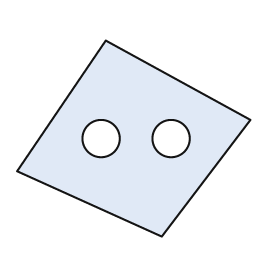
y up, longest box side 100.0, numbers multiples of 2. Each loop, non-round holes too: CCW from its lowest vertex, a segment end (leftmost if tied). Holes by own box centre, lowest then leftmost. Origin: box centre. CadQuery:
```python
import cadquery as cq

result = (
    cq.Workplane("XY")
    .moveTo(12.0, -42.0)
    .lineTo(50.0, 8.0)
    .lineTo(-12.0, 42.0)
    .lineTo(-50.0, -14.0)
    .close()
    .moveTo(-14.0, 0.0)
    .circle(8.0)
    .moveTo(16.0, 0.0)
    .circle(8.0)
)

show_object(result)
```